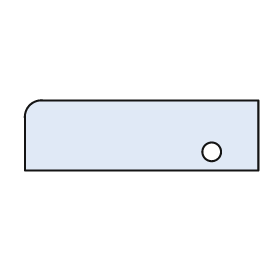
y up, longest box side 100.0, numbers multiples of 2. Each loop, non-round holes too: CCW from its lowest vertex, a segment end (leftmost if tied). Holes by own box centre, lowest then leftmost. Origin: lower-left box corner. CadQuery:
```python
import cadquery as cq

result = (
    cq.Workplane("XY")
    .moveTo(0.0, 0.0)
    .lineTo(100.0, 0.0)
    .lineTo(100.0, 30.0)
    .lineTo(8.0, 30.0)
    .threePointArc((2.0, 28.0), (0.0, 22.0))
    .close()
    .moveTo(80.0, 8.0)
    .circle(4.0)
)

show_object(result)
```